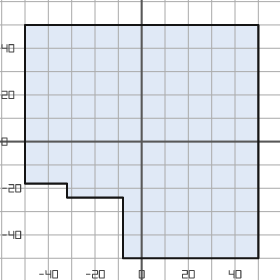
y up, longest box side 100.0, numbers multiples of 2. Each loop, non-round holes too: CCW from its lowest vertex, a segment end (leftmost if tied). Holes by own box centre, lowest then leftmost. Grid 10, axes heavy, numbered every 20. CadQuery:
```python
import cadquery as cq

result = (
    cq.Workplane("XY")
    .moveTo(-8.0, -50.0)
    .lineTo(50.0, -50.0)
    .lineTo(50.0, 50.0)
    .lineTo(-50.0, 50.0)
    .lineTo(-50.0, -18.0)
    .lineTo(-32.0, -18.0)
    .lineTo(-32.0, -24.0)
    .lineTo(-8.0, -24.0)
    .close()
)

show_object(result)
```